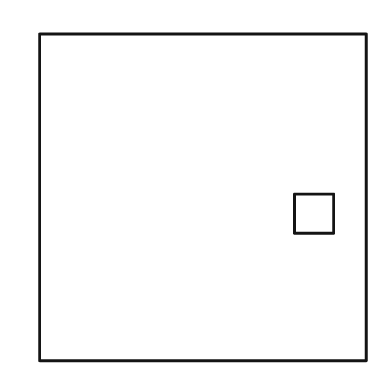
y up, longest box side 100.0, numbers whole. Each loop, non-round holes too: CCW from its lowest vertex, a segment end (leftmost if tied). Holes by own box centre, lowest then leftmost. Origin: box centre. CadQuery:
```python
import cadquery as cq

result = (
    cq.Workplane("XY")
    .moveTo(-50.0, -50.0)
    .lineTo(50.0, -50.0)
    .lineTo(50.0, 50.0)
    .lineTo(-50.0, 50.0)
    .close()
    .moveTo(28.0, -11.0)
    .lineTo(40.0, -11.0)
    .lineTo(40.0, 1.0)
    .lineTo(28.0, 1.0)
    .close()
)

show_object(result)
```